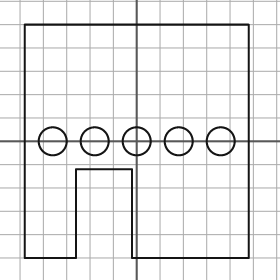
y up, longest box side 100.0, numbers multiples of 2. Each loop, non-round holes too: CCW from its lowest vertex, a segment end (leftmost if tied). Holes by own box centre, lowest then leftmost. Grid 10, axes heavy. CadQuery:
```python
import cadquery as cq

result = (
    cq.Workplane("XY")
    .moveTo(-48.0, -50.0)
    .lineTo(-26.0, -50.0)
    .lineTo(-26.0, -12.0)
    .lineTo(-2.0, -12.0)
    .lineTo(-2.0, -50.0)
    .lineTo(48.0, -50.0)
    .lineTo(48.0, 50.0)
    .lineTo(-48.0, 50.0)
    .close()
    .moveTo(-36.0, 0.0)
    .circle(6.0)
    .moveTo(-18.0, 0.0)
    .circle(6.0)
    .moveTo(0.0, 0.0)
    .circle(6.0)
    .moveTo(18.0, 0.0)
    .circle(6.0)
    .moveTo(36.0, 0.0)
    .circle(6.0)
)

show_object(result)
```